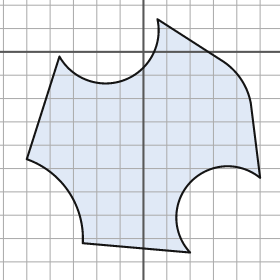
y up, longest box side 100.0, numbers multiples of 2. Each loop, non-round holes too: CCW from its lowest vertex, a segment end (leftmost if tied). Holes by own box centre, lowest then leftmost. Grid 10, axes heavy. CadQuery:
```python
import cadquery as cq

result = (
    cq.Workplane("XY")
    .moveTo(20.0, -86.0)
    .threePointArc((20.0, -56.0), (50.0, -54.0))
    .lineTo(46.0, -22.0)
    .threePointArc((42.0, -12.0), (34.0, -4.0))
    .lineTo(6.0, 14.0)
    .threePointArc((-8.0, -12.0), (-36.0, -2.0))
    .lineTo(-50.0, -46.0)
    .threePointArc((-32.0, -60.0), (-26.0, -82.0))
    .close()
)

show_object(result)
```